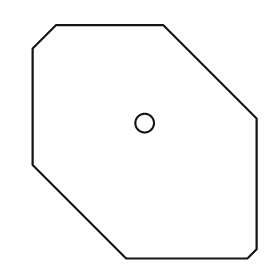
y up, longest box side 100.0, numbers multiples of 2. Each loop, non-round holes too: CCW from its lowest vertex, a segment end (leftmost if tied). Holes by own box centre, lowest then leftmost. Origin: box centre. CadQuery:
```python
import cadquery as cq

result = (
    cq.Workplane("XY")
    .moveTo(-8.0, -50.0)
    .lineTo(44.0, -50.0)
    .lineTo(48.0, -46.0)
    .lineTo(48.0, 10.0)
    .lineTo(8.0, 50.0)
    .lineTo(-38.0, 50.0)
    .lineTo(-48.0, 40.0)
    .lineTo(-48.0, -10.0)
    .close()
    .moveTo(0.0, 8.0)
    .circle(4.0)
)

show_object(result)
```